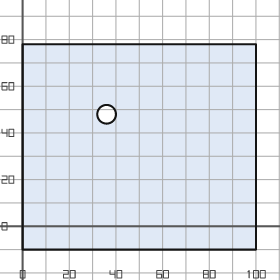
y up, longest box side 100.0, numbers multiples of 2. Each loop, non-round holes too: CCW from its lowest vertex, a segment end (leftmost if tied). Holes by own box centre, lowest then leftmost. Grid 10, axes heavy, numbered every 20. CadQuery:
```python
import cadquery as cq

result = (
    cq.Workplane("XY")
    .moveTo(0.0, -10.0)
    .lineTo(100.0, -10.0)
    .lineTo(100.0, 78.0)
    .lineTo(0.0, 78.0)
    .close()
    .moveTo(36.0, 48.0)
    .circle(4.0)
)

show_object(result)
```